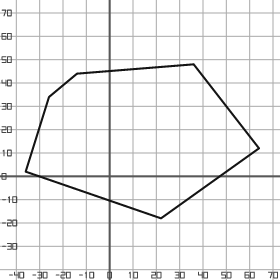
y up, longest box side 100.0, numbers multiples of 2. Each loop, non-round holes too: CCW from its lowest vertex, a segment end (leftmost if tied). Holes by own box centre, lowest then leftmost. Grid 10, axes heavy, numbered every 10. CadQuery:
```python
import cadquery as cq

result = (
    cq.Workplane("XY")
    .moveTo(22.0, -18.0)
    .lineTo(64.0, 12.0)
    .lineTo(36.0, 48.0)
    .lineTo(-14.0, 44.0)
    .lineTo(-26.0, 34.0)
    .lineTo(-36.0, 2.0)
    .close()
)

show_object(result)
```